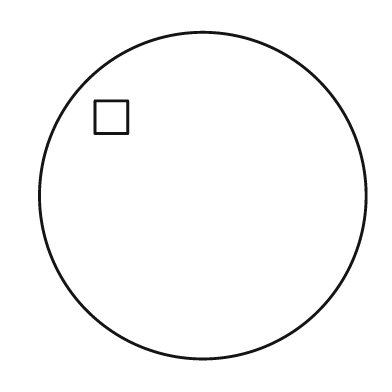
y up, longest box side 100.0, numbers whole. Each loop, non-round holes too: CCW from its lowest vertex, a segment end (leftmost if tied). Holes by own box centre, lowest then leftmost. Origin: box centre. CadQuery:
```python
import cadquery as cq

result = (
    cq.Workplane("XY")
    .moveTo(0.0, 0.0)
    .circle(50.0)
    .moveTo(-33.0, 19.0)
    .lineTo(-23.0, 19.0)
    .lineTo(-23.0, 29.0)
    .lineTo(-33.0, 29.0)
    .close()
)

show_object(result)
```